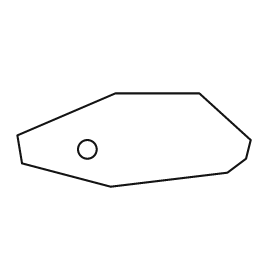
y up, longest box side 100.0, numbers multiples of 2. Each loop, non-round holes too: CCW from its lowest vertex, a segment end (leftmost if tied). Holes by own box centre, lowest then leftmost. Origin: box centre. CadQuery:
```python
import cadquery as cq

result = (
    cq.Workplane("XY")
    .moveTo(-10.0, -20.0)
    .lineTo(40.0, -14.0)
    .lineTo(48.0, -8.0)
    .lineTo(50.0, 0.0)
    .lineTo(28.0, 20.0)
    .lineTo(-8.0, 20.0)
    .lineTo(-50.0, 2.0)
    .lineTo(-48.0, -10.0)
    .close()
    .moveTo(-20.0, -4.0)
    .circle(4.0)
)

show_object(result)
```